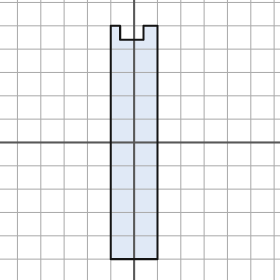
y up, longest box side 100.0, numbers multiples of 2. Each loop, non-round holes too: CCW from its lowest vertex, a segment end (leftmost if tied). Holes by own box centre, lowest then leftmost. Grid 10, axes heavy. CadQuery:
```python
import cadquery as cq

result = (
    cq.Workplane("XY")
    .moveTo(-10.0, -50.0)
    .lineTo(10.0, -50.0)
    .lineTo(10.0, 50.0)
    .lineTo(4.0, 50.0)
    .lineTo(4.0, 44.0)
    .lineTo(-6.0, 44.0)
    .lineTo(-6.0, 50.0)
    .lineTo(-10.0, 50.0)
    .close()
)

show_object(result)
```